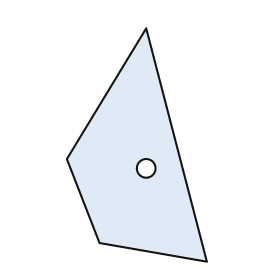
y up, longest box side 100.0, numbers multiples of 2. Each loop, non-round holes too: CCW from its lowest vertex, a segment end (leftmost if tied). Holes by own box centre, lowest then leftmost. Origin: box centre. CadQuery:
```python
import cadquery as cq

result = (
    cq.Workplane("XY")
    .moveTo(30.0, -50.0)
    .lineTo(4.0, 50.0)
    .lineTo(-30.0, -6.0)
    .lineTo(-16.0, -42.0)
    .close()
    .moveTo(4.0, -10.0)
    .circle(4.0)
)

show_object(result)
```